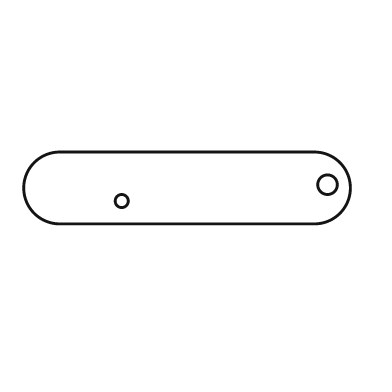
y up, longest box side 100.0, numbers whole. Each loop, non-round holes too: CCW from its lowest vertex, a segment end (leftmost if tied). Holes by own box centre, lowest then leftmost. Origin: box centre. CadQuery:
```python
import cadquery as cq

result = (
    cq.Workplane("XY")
    .moveTo(-39.0, -11.0)
    .lineTo(39.0, -11.0)
    .threePointArc((50.0, 0.0), (39.0, 11.0))
    .lineTo(-39.0, 11.0)
    .threePointArc((-50.0, 0.0), (-39.0, -11.0))
    .close()
    .moveTo(-20.0, -4.0)
    .circle(2.0)
    .moveTo(43.0, 1.0)
    .circle(3.0)
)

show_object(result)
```